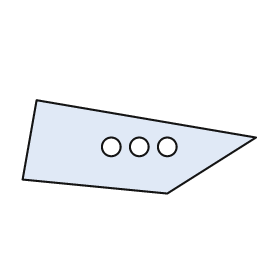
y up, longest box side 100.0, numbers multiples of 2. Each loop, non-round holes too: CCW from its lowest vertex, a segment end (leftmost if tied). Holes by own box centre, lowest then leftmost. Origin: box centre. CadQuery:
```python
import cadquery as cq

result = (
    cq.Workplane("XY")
    .moveTo(12.0, -20.0)
    .lineTo(50.0, 4.0)
    .lineTo(-44.0, 20.0)
    .lineTo(-50.0, -14.0)
    .close()
    .moveTo(-12.0, 0.0)
    .circle(4.0)
    .moveTo(0.0, 0.0)
    .circle(4.0)
    .moveTo(12.0, 0.0)
    .circle(4.0)
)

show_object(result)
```